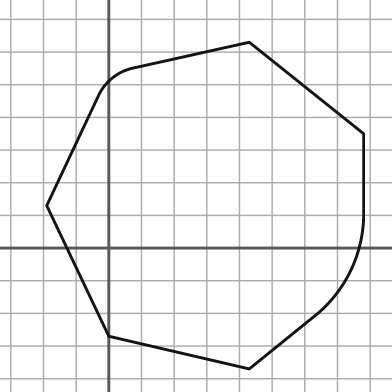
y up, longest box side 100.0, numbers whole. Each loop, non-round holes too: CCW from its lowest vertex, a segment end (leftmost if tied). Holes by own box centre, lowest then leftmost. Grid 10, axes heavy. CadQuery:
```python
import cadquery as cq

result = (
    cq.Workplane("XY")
    .moveTo(43.0, -37.0)
    .lineTo(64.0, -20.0)
    .threePointArc((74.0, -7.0), (78.0, 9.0))
    .lineTo(78.0, 35.0)
    .lineTo(43.0, 63.0)
    .lineTo(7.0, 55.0)
    .threePointArc((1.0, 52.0), (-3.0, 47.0))
    .lineTo(-19.0, 13.0)
    .lineTo(0.0, -27.0)
    .close()
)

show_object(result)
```